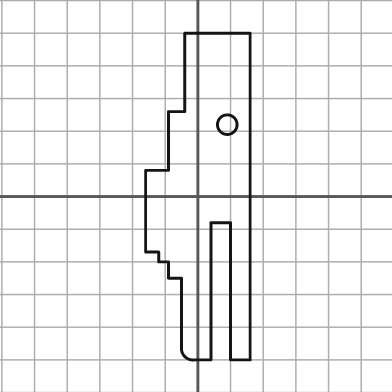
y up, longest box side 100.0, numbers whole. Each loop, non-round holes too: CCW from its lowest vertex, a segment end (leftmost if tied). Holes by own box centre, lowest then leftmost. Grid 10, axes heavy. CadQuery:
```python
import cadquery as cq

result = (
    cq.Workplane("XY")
    .moveTo(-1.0, -50.0)
    .lineTo(4.0, -50.0)
    .lineTo(4.0, -8.0)
    .lineTo(10.0, -8.0)
    .lineTo(10.0, -50.0)
    .lineTo(16.0, -50.0)
    .lineTo(16.0, 50.0)
    .lineTo(-4.0, 50.0)
    .lineTo(-4.0, 26.0)
    .lineTo(-9.0, 26.0)
    .lineTo(-9.0, 8.0)
    .lineTo(-16.0, 8.0)
    .lineTo(-16.0, -17.0)
    .lineTo(-12.0, -17.0)
    .lineTo(-12.0, -20.0)
    .lineTo(-9.0, -20.0)
    .lineTo(-9.0, -25.0)
    .lineTo(-5.0, -25.0)
    .lineTo(-5.0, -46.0)
    .threePointArc((-4.0, -49.0), (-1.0, -50.0))
    .close()
    .moveTo(9.0, 22.0)
    .circle(3.0)
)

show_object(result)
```